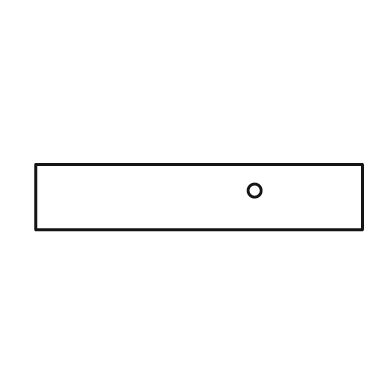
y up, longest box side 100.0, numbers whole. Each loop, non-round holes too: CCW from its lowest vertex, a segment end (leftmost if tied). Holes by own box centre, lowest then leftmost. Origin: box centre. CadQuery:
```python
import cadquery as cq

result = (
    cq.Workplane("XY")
    .moveTo(-50.0, -10.0)
    .lineTo(50.0, -10.0)
    .lineTo(50.0, 10.0)
    .lineTo(-50.0, 10.0)
    .close()
    .moveTo(17.0, 2.0)
    .circle(2.0)
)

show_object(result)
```